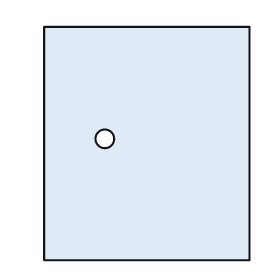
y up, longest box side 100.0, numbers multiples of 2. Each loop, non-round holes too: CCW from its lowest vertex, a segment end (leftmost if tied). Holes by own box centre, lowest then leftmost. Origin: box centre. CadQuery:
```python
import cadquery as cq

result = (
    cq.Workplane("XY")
    .moveTo(-44.0, -50.0)
    .lineTo(44.0, -50.0)
    .lineTo(44.0, 50.0)
    .lineTo(-44.0, 50.0)
    .close()
    .moveTo(-18.0, 2.0)
    .circle(4.0)
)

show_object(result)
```